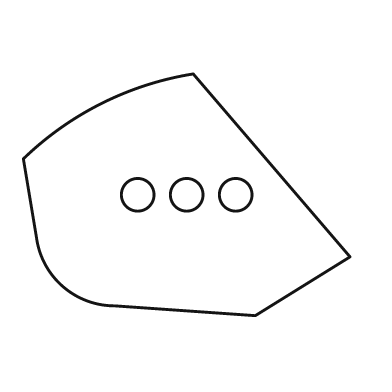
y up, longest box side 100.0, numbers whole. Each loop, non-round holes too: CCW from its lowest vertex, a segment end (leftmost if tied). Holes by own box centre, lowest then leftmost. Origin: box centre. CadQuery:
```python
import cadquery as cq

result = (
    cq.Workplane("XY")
    .moveTo(21.0, -37.0)
    .lineTo(50.0, -19.0)
    .lineTo(2.0, 37.0)
    .threePointArc((-26.0, 28.0), (-50.0, 11.0))
    .lineTo(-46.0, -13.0)
    .threePointArc((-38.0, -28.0), (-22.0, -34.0))
    .close()
    .moveTo(-15.0, 0.0)
    .circle(5.0)
    .moveTo(0.0, 0.0)
    .circle(5.0)
    .moveTo(15.0, 0.0)
    .circle(5.0)
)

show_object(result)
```